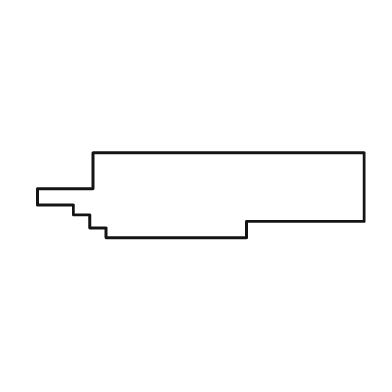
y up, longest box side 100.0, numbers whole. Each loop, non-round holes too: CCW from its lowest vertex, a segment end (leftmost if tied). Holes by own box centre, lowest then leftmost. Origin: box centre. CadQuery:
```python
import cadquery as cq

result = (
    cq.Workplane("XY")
    .moveTo(-29.0, -13.0)
    .lineTo(14.0, -13.0)
    .lineTo(14.0, -8.0)
    .lineTo(50.0, -8.0)
    .lineTo(50.0, 13.0)
    .lineTo(-33.0, 13.0)
    .lineTo(-33.0, 2.0)
    .lineTo(-50.0, 2.0)
    .lineTo(-50.0, -3.0)
    .lineTo(-39.0, -3.0)
    .lineTo(-39.0, -6.0)
    .lineTo(-34.0, -6.0)
    .lineTo(-34.0, -10.0)
    .lineTo(-29.0, -10.0)
    .close()
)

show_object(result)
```